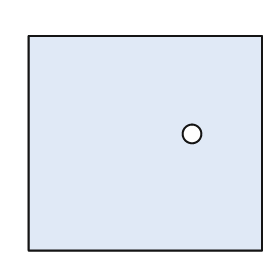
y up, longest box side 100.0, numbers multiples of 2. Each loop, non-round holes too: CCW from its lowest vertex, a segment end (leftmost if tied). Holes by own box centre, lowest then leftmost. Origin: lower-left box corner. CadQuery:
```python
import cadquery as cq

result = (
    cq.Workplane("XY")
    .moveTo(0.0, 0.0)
    .lineTo(100.0, 0.0)
    .lineTo(100.0, 92.0)
    .lineTo(0.0, 92.0)
    .close()
    .moveTo(70.0, 50.0)
    .circle(4.0)
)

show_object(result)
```